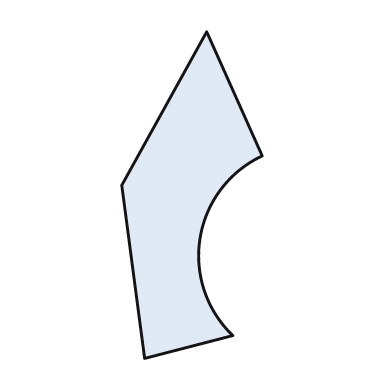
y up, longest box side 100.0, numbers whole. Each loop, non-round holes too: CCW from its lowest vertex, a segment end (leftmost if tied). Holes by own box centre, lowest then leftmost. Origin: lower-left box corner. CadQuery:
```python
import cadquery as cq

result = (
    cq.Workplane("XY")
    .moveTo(7.0, 0.0)
    .lineTo(34.0, 7.0)
    .threePointArc((24.0, 37.0), (43.0, 62.0))
    .lineTo(26.0, 100.0)
    .lineTo(0.0, 53.0)
    .close()
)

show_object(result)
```